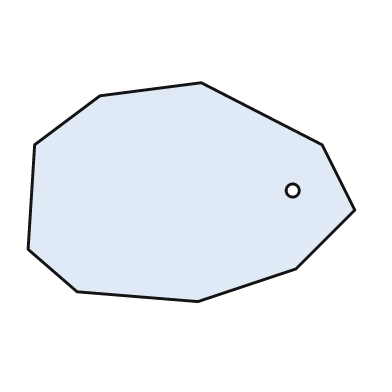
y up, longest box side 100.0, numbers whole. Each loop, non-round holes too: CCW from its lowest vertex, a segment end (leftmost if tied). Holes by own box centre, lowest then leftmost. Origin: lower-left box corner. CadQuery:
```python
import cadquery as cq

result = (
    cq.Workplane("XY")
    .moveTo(52.0, 0.0)
    .lineTo(82.0, 10.0)
    .lineTo(100.0, 28.0)
    .lineTo(90.0, 48.0)
    .lineTo(53.0, 67.0)
    .lineTo(22.0, 63.0)
    .lineTo(2.0, 48.0)
    .lineTo(0.0, 16.0)
    .lineTo(15.0, 3.0)
    .close()
    .moveTo(81.0, 34.0)
    .circle(2.0)
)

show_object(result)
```